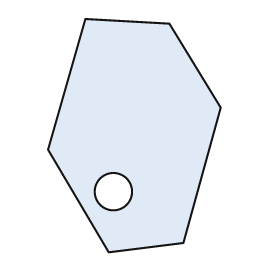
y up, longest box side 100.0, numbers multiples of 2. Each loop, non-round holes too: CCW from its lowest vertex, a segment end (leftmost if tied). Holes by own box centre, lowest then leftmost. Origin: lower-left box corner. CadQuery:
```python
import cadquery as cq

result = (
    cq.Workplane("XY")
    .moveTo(26.0, 0.0)
    .lineTo(58.0, 4.0)
    .lineTo(74.0, 62.0)
    .lineTo(52.0, 98.0)
    .lineTo(16.0, 100.0)
    .lineTo(0.0, 44.0)
    .close()
    .moveTo(28.0, 26.0)
    .circle(8.0)
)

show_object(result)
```